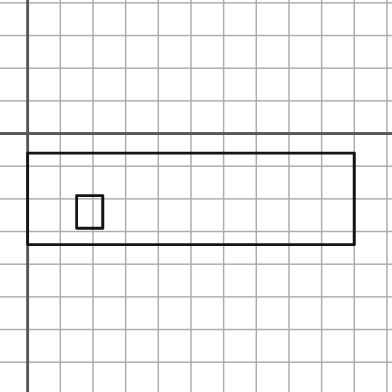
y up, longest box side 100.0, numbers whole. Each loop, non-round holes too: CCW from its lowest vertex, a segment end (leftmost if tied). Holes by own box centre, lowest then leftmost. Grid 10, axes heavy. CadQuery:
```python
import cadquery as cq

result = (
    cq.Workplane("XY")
    .moveTo(0.0, -34.0)
    .lineTo(100.0, -34.0)
    .lineTo(100.0, -6.0)
    .lineTo(0.0, -6.0)
    .close()
    .moveTo(15.0, -29.0)
    .lineTo(23.0, -29.0)
    .lineTo(23.0, -19.0)
    .lineTo(15.0, -19.0)
    .close()
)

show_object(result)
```